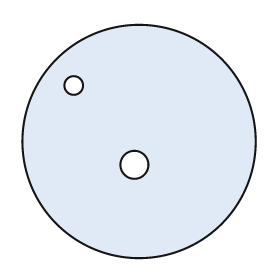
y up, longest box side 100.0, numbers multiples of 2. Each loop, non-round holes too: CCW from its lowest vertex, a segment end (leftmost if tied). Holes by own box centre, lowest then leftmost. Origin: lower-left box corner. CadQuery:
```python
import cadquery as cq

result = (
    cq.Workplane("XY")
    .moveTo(50.0, 50.0)
    .circle(50.0)
    .moveTo(48.0, 40.0)
    .circle(6.0)
    .moveTo(22.0, 74.0)
    .circle(4.0)
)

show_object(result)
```